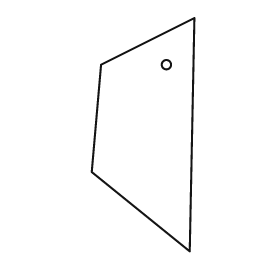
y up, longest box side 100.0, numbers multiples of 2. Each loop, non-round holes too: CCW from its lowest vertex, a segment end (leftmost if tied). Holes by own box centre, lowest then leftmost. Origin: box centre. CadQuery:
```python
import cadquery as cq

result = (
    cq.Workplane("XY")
    .moveTo(20.0, -50.0)
    .lineTo(22.0, 50.0)
    .lineTo(-18.0, 30.0)
    .lineTo(-22.0, -16.0)
    .close()
    .moveTo(10.0, 30.0)
    .circle(2.0)
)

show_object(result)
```